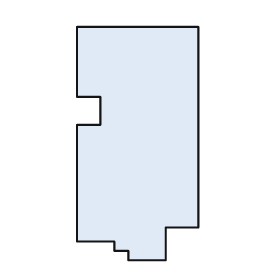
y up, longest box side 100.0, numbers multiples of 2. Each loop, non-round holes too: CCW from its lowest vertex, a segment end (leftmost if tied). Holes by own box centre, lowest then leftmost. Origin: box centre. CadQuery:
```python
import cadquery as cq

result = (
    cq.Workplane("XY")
    .moveTo(-4.0, -50.0)
    .lineTo(12.0, -50.0)
    .lineTo(12.0, -36.0)
    .lineTo(26.0, -36.0)
    .lineTo(26.0, 50.0)
    .lineTo(-26.0, 50.0)
    .lineTo(-26.0, 20.0)
    .lineTo(-16.0, 20.0)
    .lineTo(-16.0, 8.0)
    .lineTo(-26.0, 8.0)
    .lineTo(-26.0, -42.0)
    .lineTo(-10.0, -42.0)
    .lineTo(-10.0, -46.0)
    .lineTo(-4.0, -46.0)
    .close()
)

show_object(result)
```